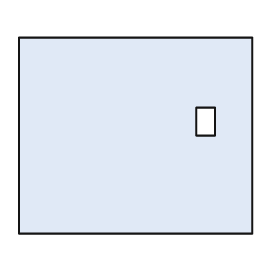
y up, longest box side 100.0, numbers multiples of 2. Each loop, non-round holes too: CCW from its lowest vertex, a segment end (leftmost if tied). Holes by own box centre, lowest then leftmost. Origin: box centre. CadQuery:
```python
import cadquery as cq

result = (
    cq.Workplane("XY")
    .moveTo(-50.0, -42.0)
    .lineTo(50.0, -42.0)
    .lineTo(50.0, 42.0)
    .lineTo(-50.0, 42.0)
    .close()
    .moveTo(26.0, 0.0)
    .lineTo(34.0, 0.0)
    .lineTo(34.0, 12.0)
    .lineTo(26.0, 12.0)
    .close()
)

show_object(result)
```